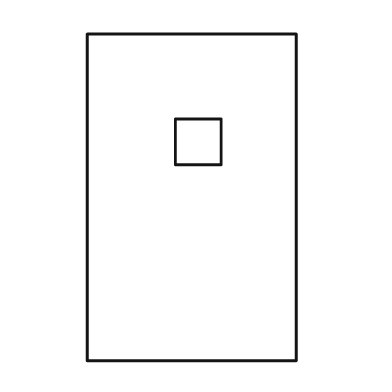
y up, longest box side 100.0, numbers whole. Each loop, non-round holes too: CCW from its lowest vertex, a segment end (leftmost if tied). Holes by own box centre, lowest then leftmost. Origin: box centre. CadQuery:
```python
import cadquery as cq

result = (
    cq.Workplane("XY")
    .moveTo(-32.0, -50.0)
    .lineTo(32.0, -50.0)
    .lineTo(32.0, 50.0)
    .lineTo(-32.0, 50.0)
    .close()
    .moveTo(-5.0, 10.0)
    .lineTo(9.0, 10.0)
    .lineTo(9.0, 24.0)
    .lineTo(-5.0, 24.0)
    .close()
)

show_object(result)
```